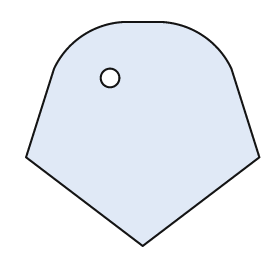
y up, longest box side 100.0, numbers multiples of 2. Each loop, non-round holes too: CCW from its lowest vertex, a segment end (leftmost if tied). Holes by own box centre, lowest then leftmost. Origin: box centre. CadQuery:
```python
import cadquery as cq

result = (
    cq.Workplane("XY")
    .moveTo(0.0, -48.0)
    .lineTo(50.0, -10.0)
    .lineTo(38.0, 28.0)
    .threePointArc((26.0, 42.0), (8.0, 48.0))
    .lineTo(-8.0, 48.0)
    .threePointArc((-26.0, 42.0), (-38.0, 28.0))
    .lineTo(-50.0, -10.0)
    .close()
    .moveTo(-14.0, 24.0)
    .circle(4.0)
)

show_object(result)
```